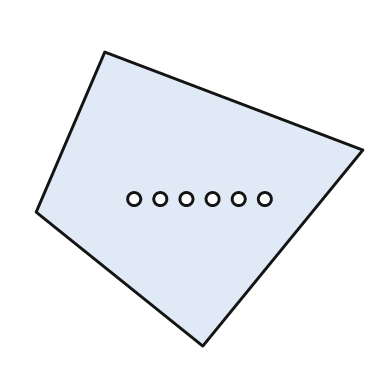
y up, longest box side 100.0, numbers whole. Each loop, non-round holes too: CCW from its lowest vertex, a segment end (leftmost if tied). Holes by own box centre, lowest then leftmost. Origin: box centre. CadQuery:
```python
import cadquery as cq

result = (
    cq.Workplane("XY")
    .moveTo(1.0, -45.0)
    .lineTo(50.0, 15.0)
    .lineTo(-29.0, 45.0)
    .lineTo(-50.0, -4.0)
    .close()
    .moveTo(-20.0, 0.0)
    .circle(2.0)
    .moveTo(-12.0, 0.0)
    .circle(2.0)
    .moveTo(-4.0, 0.0)
    .circle(2.0)
    .moveTo(4.0, 0.0)
    .circle(2.0)
    .moveTo(12.0, 0.0)
    .circle(2.0)
    .moveTo(20.0, 0.0)
    .circle(2.0)
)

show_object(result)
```